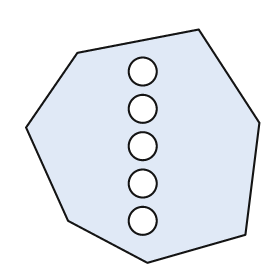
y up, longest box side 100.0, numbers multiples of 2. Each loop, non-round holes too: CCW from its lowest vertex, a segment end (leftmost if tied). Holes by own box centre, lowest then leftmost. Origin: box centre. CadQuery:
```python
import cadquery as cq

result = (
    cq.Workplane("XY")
    .moveTo(2.0, -50.0)
    .lineTo(44.0, -38.0)
    .lineTo(50.0, 10.0)
    .lineTo(24.0, 50.0)
    .lineTo(-28.0, 40.0)
    .lineTo(-50.0, 8.0)
    .lineTo(-32.0, -32.0)
    .close()
    .moveTo(0.0, -32.0)
    .circle(6.0)
    .moveTo(0.0, -16.0)
    .circle(6.0)
    .moveTo(0.0, 0.0)
    .circle(6.0)
    .moveTo(0.0, 16.0)
    .circle(6.0)
    .moveTo(0.0, 32.0)
    .circle(6.0)
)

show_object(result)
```